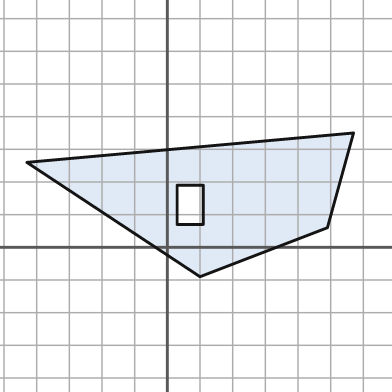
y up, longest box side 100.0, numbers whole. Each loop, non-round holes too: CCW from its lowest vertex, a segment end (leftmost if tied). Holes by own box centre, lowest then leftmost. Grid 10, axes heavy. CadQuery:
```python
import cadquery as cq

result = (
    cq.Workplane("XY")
    .moveTo(10.0, -9.0)
    .lineTo(49.0, 6.0)
    .lineTo(57.0, 35.0)
    .lineTo(-43.0, 26.0)
    .close()
    .moveTo(3.0, 7.0)
    .lineTo(11.0, 7.0)
    .lineTo(11.0, 19.0)
    .lineTo(3.0, 19.0)
    .close()
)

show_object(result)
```